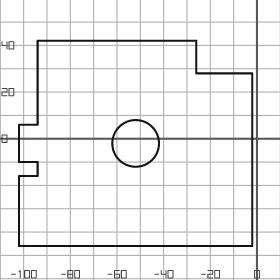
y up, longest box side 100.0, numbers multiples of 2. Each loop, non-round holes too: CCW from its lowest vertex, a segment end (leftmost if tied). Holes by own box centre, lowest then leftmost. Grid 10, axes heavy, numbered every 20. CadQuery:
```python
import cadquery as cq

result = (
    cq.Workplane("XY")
    .moveTo(-102.0, -46.0)
    .lineTo(-2.0, -46.0)
    .lineTo(-2.0, 28.0)
    .lineTo(-26.0, 28.0)
    .lineTo(-26.0, 42.0)
    .lineTo(-94.0, 42.0)
    .lineTo(-94.0, 6.0)
    .lineTo(-102.0, 6.0)
    .lineTo(-102.0, -10.0)
    .lineTo(-94.0, -10.0)
    .lineTo(-94.0, -16.0)
    .lineTo(-102.0, -16.0)
    .close()
    .moveTo(-52.0, -2.0)
    .circle(10.0)
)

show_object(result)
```